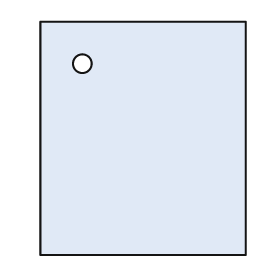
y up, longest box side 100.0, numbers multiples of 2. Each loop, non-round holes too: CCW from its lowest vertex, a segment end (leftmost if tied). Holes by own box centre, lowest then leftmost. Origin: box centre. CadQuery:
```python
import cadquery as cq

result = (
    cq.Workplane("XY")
    .moveTo(-44.0, -50.0)
    .lineTo(44.0, -50.0)
    .lineTo(44.0, 50.0)
    .lineTo(-44.0, 50.0)
    .close()
    .moveTo(-26.0, 32.0)
    .circle(4.0)
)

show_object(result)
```